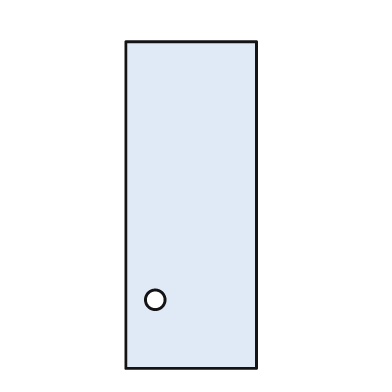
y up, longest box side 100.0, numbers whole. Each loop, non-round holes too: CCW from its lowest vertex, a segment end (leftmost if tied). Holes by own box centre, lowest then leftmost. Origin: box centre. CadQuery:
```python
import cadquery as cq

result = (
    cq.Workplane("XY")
    .moveTo(-20.0, -50.0)
    .lineTo(20.0, -50.0)
    .lineTo(20.0, 50.0)
    .lineTo(-20.0, 50.0)
    .close()
    .moveTo(-11.0, -29.0)
    .circle(3.0)
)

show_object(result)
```